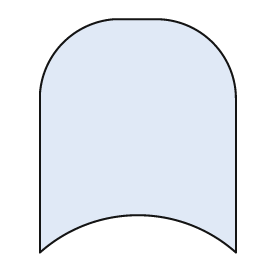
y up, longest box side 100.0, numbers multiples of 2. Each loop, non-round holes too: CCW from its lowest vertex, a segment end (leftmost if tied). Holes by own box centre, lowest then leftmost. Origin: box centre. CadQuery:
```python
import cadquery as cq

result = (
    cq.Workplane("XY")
    .moveTo(-42.0, -50.0)
    .threePointArc((0.0, -34.0), (42.0, -50.0))
    .lineTo(42.0, 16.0)
    .threePointArc((32.0, 40.0), (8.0, 50.0))
    .lineTo(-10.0, 50.0)
    .threePointArc((-32.0, 40.0), (-42.0, 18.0))
    .close()
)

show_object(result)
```